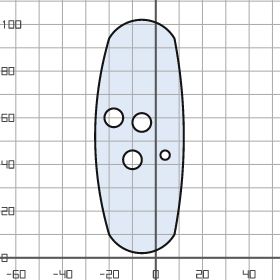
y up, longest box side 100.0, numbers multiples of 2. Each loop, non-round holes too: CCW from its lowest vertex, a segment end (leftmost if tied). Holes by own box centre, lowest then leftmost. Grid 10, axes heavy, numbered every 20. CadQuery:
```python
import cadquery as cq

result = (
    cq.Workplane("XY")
    .moveTo(-20.0, 10.0)
    .threePointArc((-6.0, 2.0), (8.0, 10.0))
    .threePointArc((12.0, 52.0), (8.0, 94.0))
    .threePointArc((-6.0, 102.0), (-20.0, 94.0))
    .threePointArc((-26.0, 52.0), (-20.0, 10.0))
    .close()
    .moveTo(-10.0, 42.0)
    .circle(4.0)
    .moveTo(4.0, 44.0)
    .circle(2.0)
    .moveTo(-6.0, 58.0)
    .circle(4.0)
    .moveTo(-18.0, 60.0)
    .circle(4.0)
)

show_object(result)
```